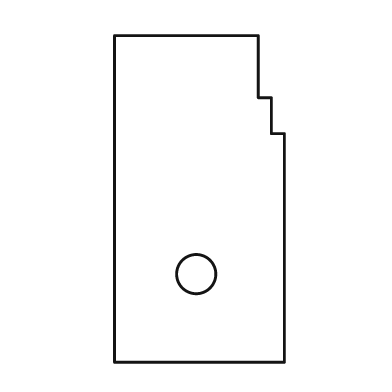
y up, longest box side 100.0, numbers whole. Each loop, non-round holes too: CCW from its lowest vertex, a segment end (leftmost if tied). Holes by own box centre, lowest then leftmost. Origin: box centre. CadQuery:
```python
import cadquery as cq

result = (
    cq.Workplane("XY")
    .moveTo(-26.0, -50.0)
    .lineTo(26.0, -50.0)
    .lineTo(26.0, 20.0)
    .lineTo(22.0, 20.0)
    .lineTo(22.0, 31.0)
    .lineTo(18.0, 31.0)
    .lineTo(18.0, 50.0)
    .lineTo(-26.0, 50.0)
    .close()
    .moveTo(-1.0, -23.0)
    .circle(6.0)
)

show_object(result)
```